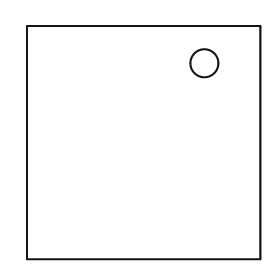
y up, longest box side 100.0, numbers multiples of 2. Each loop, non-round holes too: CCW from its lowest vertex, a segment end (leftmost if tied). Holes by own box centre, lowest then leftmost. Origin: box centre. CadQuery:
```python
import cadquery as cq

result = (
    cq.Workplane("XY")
    .moveTo(-50.0, -50.0)
    .lineTo(50.0, -50.0)
    .lineTo(50.0, 50.0)
    .lineTo(-50.0, 50.0)
    .close()
    .moveTo(26.0, 34.0)
    .circle(6.0)
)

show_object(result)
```